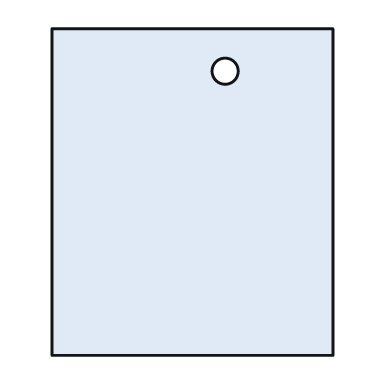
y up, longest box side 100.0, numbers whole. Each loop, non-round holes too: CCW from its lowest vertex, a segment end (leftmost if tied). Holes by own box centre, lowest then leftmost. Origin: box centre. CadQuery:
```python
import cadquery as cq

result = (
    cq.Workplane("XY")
    .moveTo(-43.0, -50.0)
    .lineTo(43.0, -50.0)
    .lineTo(43.0, 50.0)
    .lineTo(-43.0, 50.0)
    .close()
    .moveTo(10.0, 37.0)
    .circle(4.0)
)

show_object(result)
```